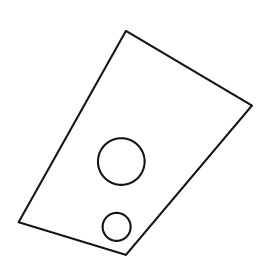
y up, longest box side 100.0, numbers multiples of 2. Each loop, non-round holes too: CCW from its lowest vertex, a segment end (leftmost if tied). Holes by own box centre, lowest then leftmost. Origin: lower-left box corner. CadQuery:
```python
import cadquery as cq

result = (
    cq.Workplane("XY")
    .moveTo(46.0, 0.0)
    .lineTo(100.0, 64.0)
    .lineTo(46.0, 96.0)
    .lineTo(0.0, 14.0)
    .close()
    .moveTo(42.0, 12.0)
    .circle(6.0)
    .moveTo(44.0, 40.0)
    .circle(10.0)
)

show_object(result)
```